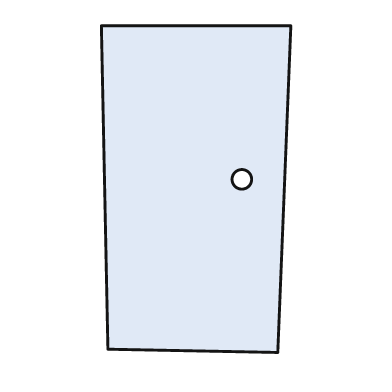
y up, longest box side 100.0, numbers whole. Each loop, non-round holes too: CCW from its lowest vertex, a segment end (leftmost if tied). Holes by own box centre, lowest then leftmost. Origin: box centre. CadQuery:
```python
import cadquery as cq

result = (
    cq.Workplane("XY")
    .moveTo(25.0, -50.0)
    .lineTo(29.0, 50.0)
    .lineTo(-29.0, 50.0)
    .lineTo(-27.0, -49.0)
    .close()
    .moveTo(14.0, 3.0)
    .circle(3.0)
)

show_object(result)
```